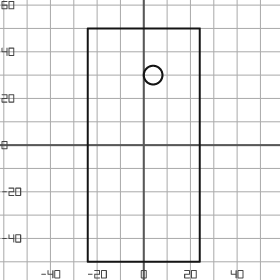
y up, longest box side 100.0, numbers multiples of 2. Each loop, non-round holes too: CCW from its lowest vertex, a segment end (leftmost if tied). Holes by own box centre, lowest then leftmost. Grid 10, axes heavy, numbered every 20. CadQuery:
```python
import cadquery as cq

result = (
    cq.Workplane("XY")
    .moveTo(-24.0, -50.0)
    .lineTo(24.0, -50.0)
    .lineTo(24.0, 50.0)
    .lineTo(-24.0, 50.0)
    .close()
    .moveTo(4.0, 30.0)
    .circle(4.0)
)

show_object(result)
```